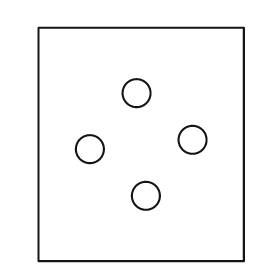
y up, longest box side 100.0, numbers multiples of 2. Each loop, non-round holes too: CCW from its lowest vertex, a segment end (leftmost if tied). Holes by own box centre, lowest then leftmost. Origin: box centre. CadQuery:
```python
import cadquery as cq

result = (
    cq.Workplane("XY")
    .moveTo(-44.0, -50.0)
    .lineTo(44.0, -50.0)
    .lineTo(44.0, 50.0)
    .lineTo(-44.0, 50.0)
    .close()
    .moveTo(2.0, -22.0)
    .circle(6.0)
    .moveTo(-22.0, -2.0)
    .circle(6.0)
    .moveTo(22.0, 2.0)
    .circle(6.0)
    .moveTo(-2.0, 22.0)
    .circle(6.0)
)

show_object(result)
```